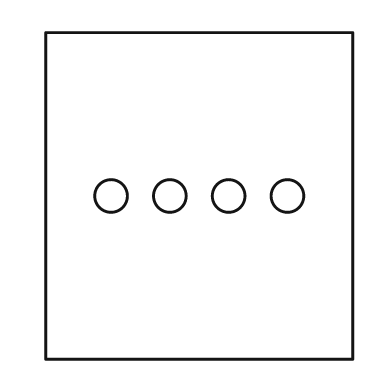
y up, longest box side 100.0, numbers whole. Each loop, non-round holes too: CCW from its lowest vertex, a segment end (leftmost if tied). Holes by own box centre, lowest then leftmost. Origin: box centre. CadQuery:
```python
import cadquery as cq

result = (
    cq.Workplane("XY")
    .moveTo(-47.0, -50.0)
    .lineTo(47.0, -50.0)
    .lineTo(47.0, 50.0)
    .lineTo(-47.0, 50.0)
    .close()
    .moveTo(-27.0, 0.0)
    .circle(5.0)
    .moveTo(-9.0, 0.0)
    .circle(5.0)
    .moveTo(9.0, 0.0)
    .circle(5.0)
    .moveTo(27.0, 0.0)
    .circle(5.0)
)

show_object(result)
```